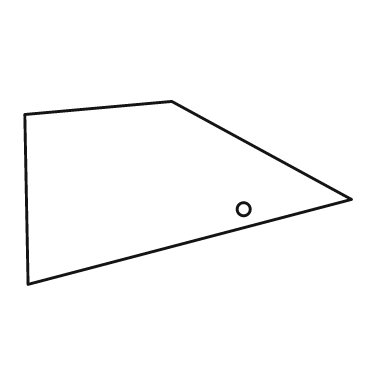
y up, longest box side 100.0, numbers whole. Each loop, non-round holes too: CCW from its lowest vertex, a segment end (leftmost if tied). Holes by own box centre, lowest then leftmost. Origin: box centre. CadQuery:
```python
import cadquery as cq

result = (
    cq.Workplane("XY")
    .moveTo(-49.0, -28.0)
    .lineTo(50.0, -2.0)
    .lineTo(-5.0, 28.0)
    .lineTo(-50.0, 24.0)
    .close()
    .moveTo(17.0, -5.0)
    .circle(2.0)
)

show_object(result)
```